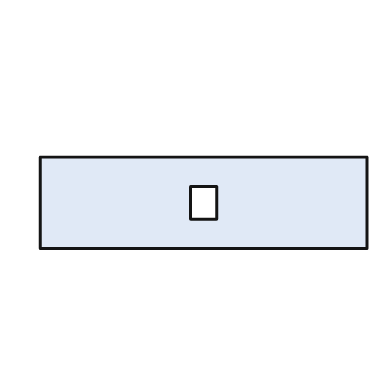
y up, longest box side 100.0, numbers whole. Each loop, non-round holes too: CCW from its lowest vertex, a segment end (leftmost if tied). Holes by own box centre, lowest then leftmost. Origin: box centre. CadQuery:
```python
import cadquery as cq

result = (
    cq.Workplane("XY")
    .moveTo(-50.0, -14.0)
    .lineTo(50.0, -14.0)
    .lineTo(50.0, 14.0)
    .lineTo(-50.0, 14.0)
    .close()
    .moveTo(-4.0, -5.0)
    .lineTo(4.0, -5.0)
    .lineTo(4.0, 5.0)
    .lineTo(-4.0, 5.0)
    .close()
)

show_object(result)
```